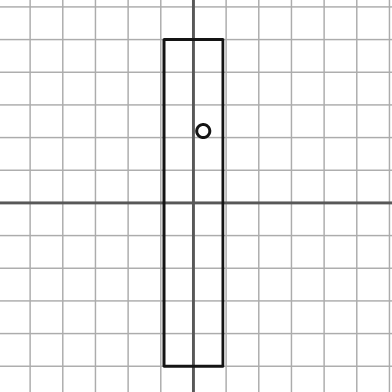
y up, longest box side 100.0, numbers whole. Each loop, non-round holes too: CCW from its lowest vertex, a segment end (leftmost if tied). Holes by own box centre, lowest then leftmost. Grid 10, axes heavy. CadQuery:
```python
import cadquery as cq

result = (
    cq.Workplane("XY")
    .moveTo(-9.0, -50.0)
    .lineTo(9.0, -50.0)
    .lineTo(9.0, 50.0)
    .lineTo(-9.0, 50.0)
    .close()
    .moveTo(3.0, 22.0)
    .circle(2.0)
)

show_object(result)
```